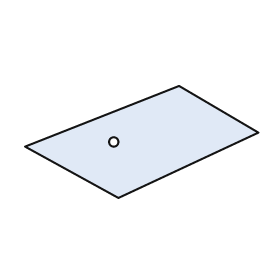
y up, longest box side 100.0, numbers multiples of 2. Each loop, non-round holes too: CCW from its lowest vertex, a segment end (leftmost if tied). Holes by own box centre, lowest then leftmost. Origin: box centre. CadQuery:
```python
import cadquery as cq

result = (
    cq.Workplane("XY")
    .moveTo(-10.0, -24.0)
    .lineTo(50.0, 4.0)
    .lineTo(16.0, 24.0)
    .lineTo(-50.0, -2.0)
    .close()
    .moveTo(-12.0, 0.0)
    .circle(2.0)
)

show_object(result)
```